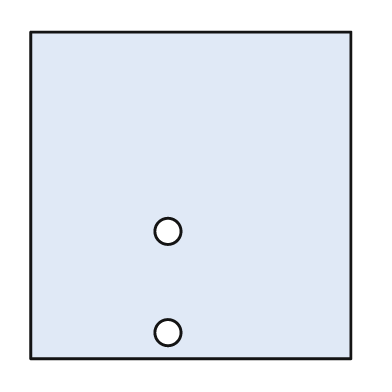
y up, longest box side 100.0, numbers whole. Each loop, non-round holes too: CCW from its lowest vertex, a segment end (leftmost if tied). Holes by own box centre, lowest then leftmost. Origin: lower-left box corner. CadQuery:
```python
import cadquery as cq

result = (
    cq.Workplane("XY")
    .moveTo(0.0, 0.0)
    .lineTo(98.0, 0.0)
    .lineTo(98.0, 100.0)
    .lineTo(0.0, 100.0)
    .close()
    .moveTo(42.0, 8.0)
    .circle(4.0)
    .moveTo(42.0, 39.0)
    .circle(4.0)
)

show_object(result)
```